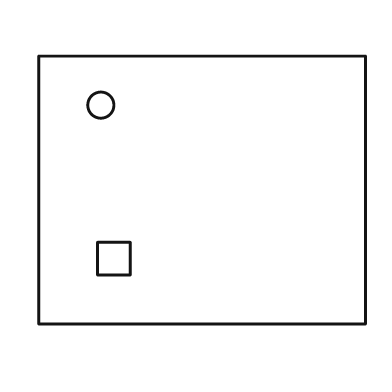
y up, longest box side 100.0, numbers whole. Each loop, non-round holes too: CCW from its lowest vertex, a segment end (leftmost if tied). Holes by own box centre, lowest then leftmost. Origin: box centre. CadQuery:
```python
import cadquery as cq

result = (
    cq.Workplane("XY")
    .moveTo(-50.0, -41.0)
    .lineTo(50.0, -41.0)
    .lineTo(50.0, 41.0)
    .lineTo(-50.0, 41.0)
    .close()
    .moveTo(-32.0, -26.0)
    .lineTo(-22.0, -26.0)
    .lineTo(-22.0, -16.0)
    .lineTo(-32.0, -16.0)
    .close()
    .moveTo(-31.0, 26.0)
    .circle(4.0)
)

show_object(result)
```